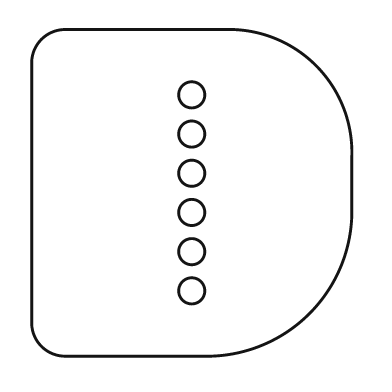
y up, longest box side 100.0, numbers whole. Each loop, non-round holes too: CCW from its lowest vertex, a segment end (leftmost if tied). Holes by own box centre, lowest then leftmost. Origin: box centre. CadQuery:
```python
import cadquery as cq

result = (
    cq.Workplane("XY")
    .moveTo(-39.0, -50.0)
    .lineTo(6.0, -50.0)
    .threePointArc((36.0, -37.0), (49.0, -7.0))
    .lineTo(49.0, 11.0)
    .threePointArc((38.0, 39.0), (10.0, 50.0))
    .lineTo(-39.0, 50.0)
    .threePointArc((-46.0, 47.0), (-49.0, 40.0))
    .lineTo(-49.0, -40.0)
    .threePointArc((-46.0, -47.0), (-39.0, -50.0))
    .close()
    .moveTo(0.0, -30.0)
    .circle(4.0)
    .moveTo(0.0, -18.0)
    .circle(4.0)
    .moveTo(0.0, -6.0)
    .circle(4.0)
    .moveTo(0.0, 6.0)
    .circle(4.0)
    .moveTo(0.0, 18.0)
    .circle(4.0)
    .moveTo(0.0, 30.0)
    .circle(4.0)
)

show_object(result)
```